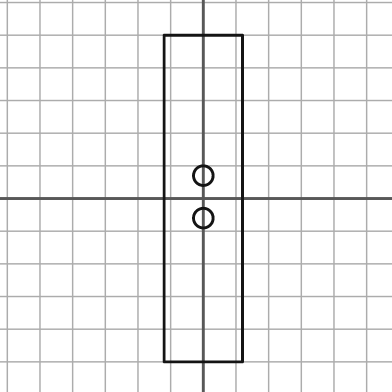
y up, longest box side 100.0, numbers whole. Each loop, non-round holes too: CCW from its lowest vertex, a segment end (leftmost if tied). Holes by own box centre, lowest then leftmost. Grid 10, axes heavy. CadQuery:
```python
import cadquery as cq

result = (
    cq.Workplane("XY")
    .moveTo(-12.0, -50.0)
    .lineTo(12.0, -50.0)
    .lineTo(12.0, 50.0)
    .lineTo(-12.0, 50.0)
    .close()
    .moveTo(0.0, -6.0)
    .circle(3.0)
    .moveTo(0.0, 7.0)
    .circle(3.0)
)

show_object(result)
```